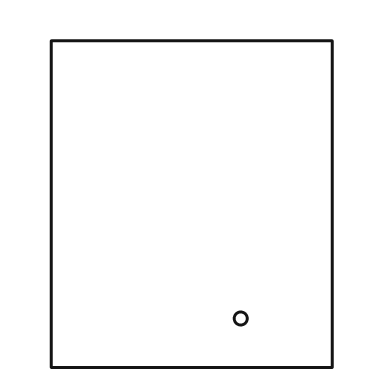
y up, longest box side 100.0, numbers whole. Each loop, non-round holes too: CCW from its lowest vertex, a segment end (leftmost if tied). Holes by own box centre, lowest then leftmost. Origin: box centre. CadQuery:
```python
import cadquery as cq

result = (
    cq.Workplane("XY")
    .moveTo(-43.0, -50.0)
    .lineTo(43.0, -50.0)
    .lineTo(43.0, 50.0)
    .lineTo(-43.0, 50.0)
    .close()
    .moveTo(15.0, -35.0)
    .circle(2.0)
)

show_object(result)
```